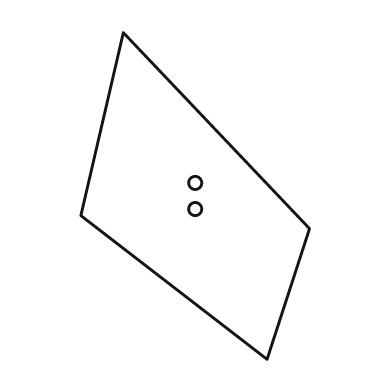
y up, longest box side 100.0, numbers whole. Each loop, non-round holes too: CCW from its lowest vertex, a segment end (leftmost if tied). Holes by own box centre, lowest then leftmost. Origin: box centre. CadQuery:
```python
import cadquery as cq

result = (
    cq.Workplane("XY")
    .moveTo(22.0, -50.0)
    .lineTo(35.0, -10.0)
    .lineTo(-22.0, 50.0)
    .lineTo(-35.0, -6.0)
    .close()
    .moveTo(0.0, -4.0)
    .circle(2.0)
    .moveTo(0.0, 4.0)
    .circle(2.0)
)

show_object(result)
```